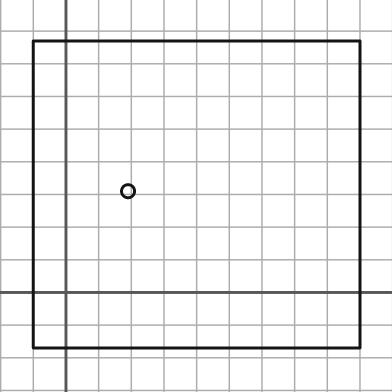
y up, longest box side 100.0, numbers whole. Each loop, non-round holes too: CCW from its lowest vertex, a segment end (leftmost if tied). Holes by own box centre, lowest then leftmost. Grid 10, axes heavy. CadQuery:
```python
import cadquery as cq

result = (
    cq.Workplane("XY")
    .moveTo(-10.0, -17.0)
    .lineTo(90.0, -17.0)
    .lineTo(90.0, 77.0)
    .lineTo(-10.0, 77.0)
    .close()
    .moveTo(19.0, 31.0)
    .circle(2.0)
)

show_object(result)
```